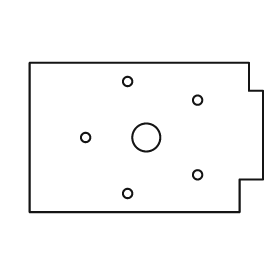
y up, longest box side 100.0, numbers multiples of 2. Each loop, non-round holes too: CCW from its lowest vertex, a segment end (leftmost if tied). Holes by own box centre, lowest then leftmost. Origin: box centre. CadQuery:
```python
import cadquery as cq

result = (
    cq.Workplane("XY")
    .moveTo(-50.0, -32.0)
    .lineTo(40.0, -32.0)
    .lineTo(40.0, -18.0)
    .lineTo(50.0, -18.0)
    .lineTo(50.0, 20.0)
    .lineTo(44.0, 20.0)
    .lineTo(44.0, 32.0)
    .lineTo(-50.0, 32.0)
    .close()
    .moveTo(-8.0, -24.0)
    .circle(2.0)
    .moveTo(22.0, -16.0)
    .circle(2.0)
    .moveTo(-26.0, 0.0)
    .circle(2.0)
    .moveTo(0.0, 0.0)
    .circle(6.0)
    .moveTo(22.0, 16.0)
    .circle(2.0)
    .moveTo(-8.0, 24.0)
    .circle(2.0)
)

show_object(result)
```